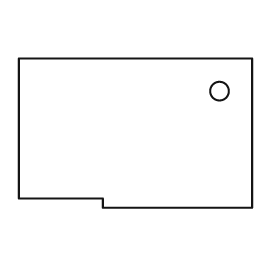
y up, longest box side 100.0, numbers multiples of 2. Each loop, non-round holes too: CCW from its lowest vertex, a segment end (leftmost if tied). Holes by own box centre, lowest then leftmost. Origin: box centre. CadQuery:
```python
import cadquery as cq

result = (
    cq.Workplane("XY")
    .moveTo(-14.0, -32.0)
    .lineTo(50.0, -32.0)
    .lineTo(50.0, 32.0)
    .lineTo(-50.0, 32.0)
    .lineTo(-50.0, -28.0)
    .lineTo(-14.0, -28.0)
    .close()
    .moveTo(36.0, 18.0)
    .circle(4.0)
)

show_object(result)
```